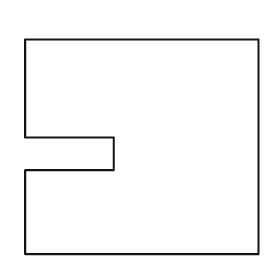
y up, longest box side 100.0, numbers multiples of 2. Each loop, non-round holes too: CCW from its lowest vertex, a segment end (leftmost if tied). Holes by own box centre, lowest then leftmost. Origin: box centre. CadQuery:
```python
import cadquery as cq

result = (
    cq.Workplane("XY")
    .moveTo(-50.0, -46.0)
    .lineTo(50.0, -46.0)
    .lineTo(50.0, 46.0)
    .lineTo(-50.0, 46.0)
    .lineTo(-50.0, 4.0)
    .lineTo(-12.0, 4.0)
    .lineTo(-12.0, -10.0)
    .lineTo(-50.0, -10.0)
    .close()
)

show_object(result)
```